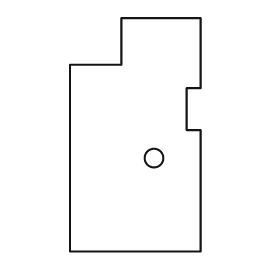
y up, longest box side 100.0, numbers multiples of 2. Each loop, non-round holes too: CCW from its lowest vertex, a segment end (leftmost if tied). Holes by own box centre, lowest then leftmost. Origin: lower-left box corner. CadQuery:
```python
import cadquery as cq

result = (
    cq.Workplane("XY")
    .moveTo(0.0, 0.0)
    .lineTo(56.0, 0.0)
    .lineTo(56.0, 52.0)
    .lineTo(50.0, 52.0)
    .lineTo(50.0, 70.0)
    .lineTo(56.0, 70.0)
    .lineTo(56.0, 100.0)
    .lineTo(22.0, 100.0)
    .lineTo(22.0, 80.0)
    .lineTo(0.0, 80.0)
    .close()
    .moveTo(36.0, 40.0)
    .circle(4.0)
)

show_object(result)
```